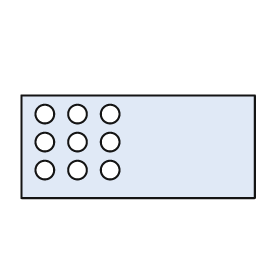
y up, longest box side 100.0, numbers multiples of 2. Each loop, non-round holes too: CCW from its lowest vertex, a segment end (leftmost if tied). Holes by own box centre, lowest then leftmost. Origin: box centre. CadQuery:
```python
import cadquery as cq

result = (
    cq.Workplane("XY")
    .moveTo(-50.0, -22.0)
    .lineTo(50.0, -22.0)
    .lineTo(50.0, 22.0)
    .lineTo(-50.0, 22.0)
    .close()
    .moveTo(-40.0, -10.0)
    .circle(4.0)
    .moveTo(-26.0, -10.0)
    .circle(4.0)
    .moveTo(-12.0, -10.0)
    .circle(4.0)
    .moveTo(-40.0, 2.0)
    .circle(4.0)
    .moveTo(-26.0, 2.0)
    .circle(4.0)
    .moveTo(-12.0, 2.0)
    .circle(4.0)
    .moveTo(-40.0, 14.0)
    .circle(4.0)
    .moveTo(-26.0, 14.0)
    .circle(4.0)
    .moveTo(-12.0, 14.0)
    .circle(4.0)
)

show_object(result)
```